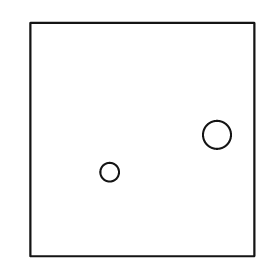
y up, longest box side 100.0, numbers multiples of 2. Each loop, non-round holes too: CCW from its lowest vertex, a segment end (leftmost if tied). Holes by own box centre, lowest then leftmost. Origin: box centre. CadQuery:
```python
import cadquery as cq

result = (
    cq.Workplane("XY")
    .moveTo(-48.0, -50.0)
    .lineTo(48.0, -50.0)
    .lineTo(48.0, 50.0)
    .lineTo(-48.0, 50.0)
    .close()
    .moveTo(-14.0, -14.0)
    .circle(4.0)
    .moveTo(32.0, 2.0)
    .circle(6.0)
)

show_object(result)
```